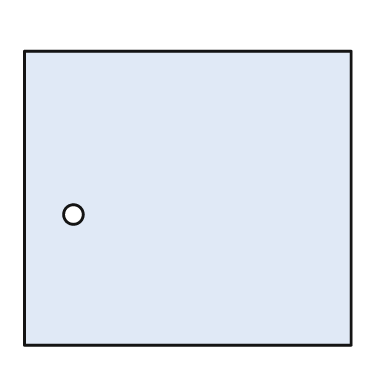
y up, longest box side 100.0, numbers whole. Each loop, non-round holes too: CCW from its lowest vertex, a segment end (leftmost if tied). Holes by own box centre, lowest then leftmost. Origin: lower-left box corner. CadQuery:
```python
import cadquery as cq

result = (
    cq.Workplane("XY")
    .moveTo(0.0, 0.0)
    .lineTo(100.0, 0.0)
    .lineTo(100.0, 90.0)
    .lineTo(0.0, 90.0)
    .close()
    .moveTo(15.0, 40.0)
    .circle(3.0)
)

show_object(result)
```